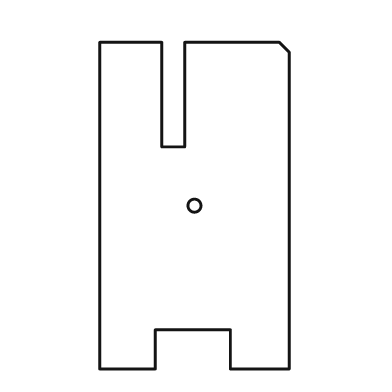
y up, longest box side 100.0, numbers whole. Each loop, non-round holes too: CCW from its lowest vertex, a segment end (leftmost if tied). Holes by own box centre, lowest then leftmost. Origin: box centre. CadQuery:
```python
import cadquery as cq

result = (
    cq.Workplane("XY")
    .moveTo(-29.0, -50.0)
    .lineTo(-12.0, -50.0)
    .lineTo(-12.0, -38.0)
    .lineTo(11.0, -38.0)
    .lineTo(11.0, -50.0)
    .lineTo(29.0, -50.0)
    .lineTo(29.0, 47.0)
    .lineTo(26.0, 50.0)
    .lineTo(-3.0, 50.0)
    .lineTo(-3.0, 18.0)
    .lineTo(-10.0, 18.0)
    .lineTo(-10.0, 50.0)
    .lineTo(-29.0, 50.0)
    .close()
    .moveTo(0.0, 0.0)
    .circle(2.0)
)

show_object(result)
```